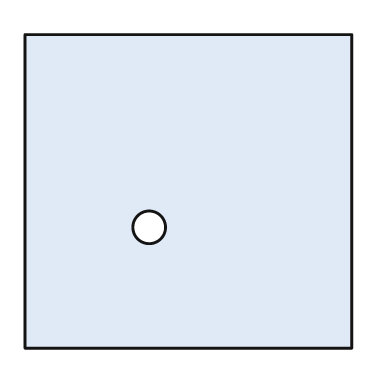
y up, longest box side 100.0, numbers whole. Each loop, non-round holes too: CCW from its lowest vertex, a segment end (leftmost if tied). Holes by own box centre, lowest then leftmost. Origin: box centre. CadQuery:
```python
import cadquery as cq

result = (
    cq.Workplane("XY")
    .moveTo(-50.0, -48.0)
    .lineTo(50.0, -48.0)
    .lineTo(50.0, 48.0)
    .lineTo(-50.0, 48.0)
    .close()
    .moveTo(-12.0, -11.0)
    .circle(5.0)
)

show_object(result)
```